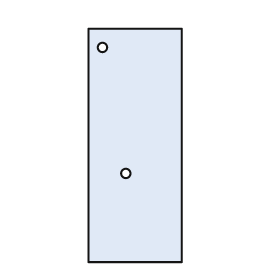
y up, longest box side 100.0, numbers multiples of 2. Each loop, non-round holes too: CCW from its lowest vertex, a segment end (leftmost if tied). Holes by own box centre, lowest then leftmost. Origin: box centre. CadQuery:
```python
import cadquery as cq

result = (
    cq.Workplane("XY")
    .moveTo(-20.0, -50.0)
    .lineTo(20.0, -50.0)
    .lineTo(20.0, 50.0)
    .lineTo(-20.0, 50.0)
    .close()
    .moveTo(-4.0, -12.0)
    .circle(2.0)
    .moveTo(-14.0, 42.0)
    .circle(2.0)
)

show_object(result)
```